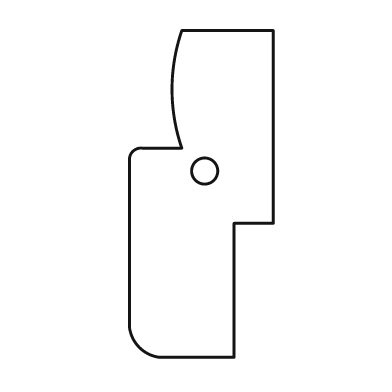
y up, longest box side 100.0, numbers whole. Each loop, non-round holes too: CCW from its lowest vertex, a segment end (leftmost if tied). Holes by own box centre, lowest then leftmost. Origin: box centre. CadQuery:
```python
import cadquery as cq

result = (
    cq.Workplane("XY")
    .moveTo(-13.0, -50.0)
    .lineTo(10.0, -50.0)
    .lineTo(10.0, -9.0)
    .lineTo(22.0, -9.0)
    .lineTo(22.0, 50.0)
    .lineTo(-6.0, 50.0)
    .threePointArc((-9.0, 32.0), (-6.0, 14.0))
    .lineTo(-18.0, 14.0)
    .threePointArc((-21.0, 13.0), (-22.0, 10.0))
    .lineTo(-22.0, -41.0)
    .threePointArc((-19.0, -47.0), (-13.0, -50.0))
    .close()
    .moveTo(1.0, 7.0)
    .circle(4.0)
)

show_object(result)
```